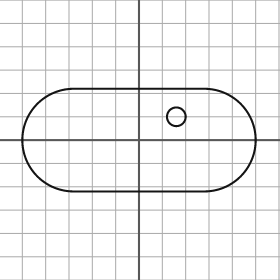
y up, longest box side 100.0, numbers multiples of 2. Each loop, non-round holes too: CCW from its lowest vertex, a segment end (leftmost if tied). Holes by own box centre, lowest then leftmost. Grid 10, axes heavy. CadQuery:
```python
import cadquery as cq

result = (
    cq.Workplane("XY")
    .moveTo(-28.0, -22.0)
    .lineTo(28.0, -22.0)
    .threePointArc((50.0, 0.0), (28.0, 22.0))
    .lineTo(-28.0, 22.0)
    .threePointArc((-50.0, 0.0), (-28.0, -22.0))
    .close()
    .moveTo(16.0, 10.0)
    .circle(4.0)
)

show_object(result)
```